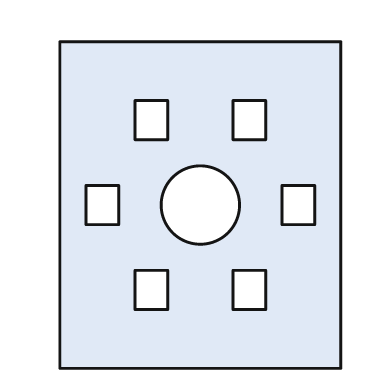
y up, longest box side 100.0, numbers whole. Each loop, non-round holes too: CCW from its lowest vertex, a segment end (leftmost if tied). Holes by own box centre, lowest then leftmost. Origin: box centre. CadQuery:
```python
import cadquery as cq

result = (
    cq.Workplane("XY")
    .moveTo(-43.0, -50.0)
    .lineTo(43.0, -50.0)
    .lineTo(43.0, 50.0)
    .lineTo(-43.0, 50.0)
    .close()
    .moveTo(-20.0, -32.0)
    .lineTo(-10.0, -32.0)
    .lineTo(-10.0, -20.0)
    .lineTo(-20.0, -20.0)
    .close()
    .moveTo(10.0, -32.0)
    .lineTo(20.0, -32.0)
    .lineTo(20.0, -20.0)
    .lineTo(10.0, -20.0)
    .close()
    .moveTo(-35.0, -6.0)
    .lineTo(-25.0, -6.0)
    .lineTo(-25.0, 6.0)
    .lineTo(-35.0, 6.0)
    .close()
    .moveTo(0.0, 0.0)
    .circle(12.0)
    .moveTo(25.0, -6.0)
    .lineTo(35.0, -6.0)
    .lineTo(35.0, 6.0)
    .lineTo(25.0, 6.0)
    .close()
    .moveTo(-20.0, 20.0)
    .lineTo(-10.0, 20.0)
    .lineTo(-10.0, 32.0)
    .lineTo(-20.0, 32.0)
    .close()
    .moveTo(10.0, 20.0)
    .lineTo(20.0, 20.0)
    .lineTo(20.0, 32.0)
    .lineTo(10.0, 32.0)
    .close()
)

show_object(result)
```